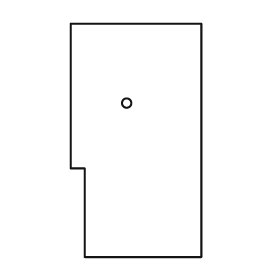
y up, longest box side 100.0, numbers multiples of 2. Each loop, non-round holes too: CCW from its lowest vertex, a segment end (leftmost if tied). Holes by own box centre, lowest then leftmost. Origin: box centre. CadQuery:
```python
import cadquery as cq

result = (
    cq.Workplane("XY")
    .moveTo(-22.0, -50.0)
    .lineTo(28.0, -50.0)
    .lineTo(28.0, 50.0)
    .lineTo(-28.0, 50.0)
    .lineTo(-28.0, -12.0)
    .lineTo(-22.0, -12.0)
    .close()
    .moveTo(-4.0, 16.0)
    .circle(2.0)
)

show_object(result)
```